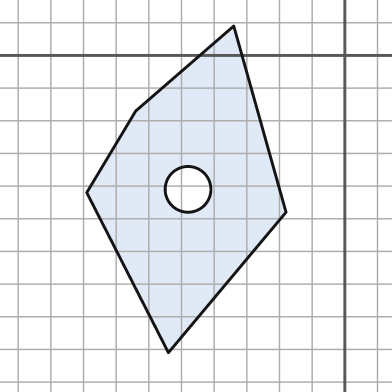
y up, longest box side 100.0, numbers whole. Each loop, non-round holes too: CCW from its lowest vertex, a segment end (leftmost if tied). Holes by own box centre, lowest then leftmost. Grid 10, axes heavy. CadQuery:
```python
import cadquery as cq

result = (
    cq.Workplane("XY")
    .moveTo(-54.0, -91.0)
    .lineTo(-18.0, -48.0)
    .lineTo(-34.0, 9.0)
    .lineTo(-64.0, -17.0)
    .lineTo(-79.0, -42.0)
    .close()
    .moveTo(-48.0, -41.0)
    .circle(7.0)
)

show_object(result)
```